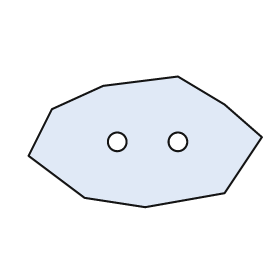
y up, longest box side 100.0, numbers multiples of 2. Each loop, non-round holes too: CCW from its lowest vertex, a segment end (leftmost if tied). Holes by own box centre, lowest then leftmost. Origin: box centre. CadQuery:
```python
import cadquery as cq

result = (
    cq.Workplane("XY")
    .moveTo(0.0, -28.0)
    .lineTo(34.0, -22.0)
    .lineTo(50.0, 2.0)
    .lineTo(34.0, 16.0)
    .lineTo(14.0, 28.0)
    .lineTo(-18.0, 24.0)
    .lineTo(-40.0, 14.0)
    .lineTo(-50.0, -6.0)
    .lineTo(-26.0, -24.0)
    .close()
    .moveTo(-12.0, 0.0)
    .circle(4.0)
    .moveTo(14.0, 0.0)
    .circle(4.0)
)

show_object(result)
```